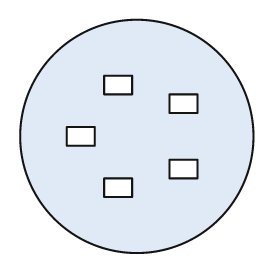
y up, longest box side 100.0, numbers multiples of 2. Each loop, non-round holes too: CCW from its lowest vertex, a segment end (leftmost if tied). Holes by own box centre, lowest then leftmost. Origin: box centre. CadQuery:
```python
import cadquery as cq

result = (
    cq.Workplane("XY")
    .moveTo(0.0, 0.0)
    .circle(50.0)
    .moveTo(-14.0, -26.0)
    .lineTo(-2.0, -26.0)
    .lineTo(-2.0, -18.0)
    .lineTo(-14.0, -18.0)
    .close()
    .moveTo(14.0, -18.0)
    .lineTo(26.0, -18.0)
    .lineTo(26.0, -10.0)
    .lineTo(14.0, -10.0)
    .close()
    .moveTo(-30.0, -4.0)
    .lineTo(-18.0, -4.0)
    .lineTo(-18.0, 4.0)
    .lineTo(-30.0, 4.0)
    .close()
    .moveTo(14.0, 10.0)
    .lineTo(26.0, 10.0)
    .lineTo(26.0, 18.0)
    .lineTo(14.0, 18.0)
    .close()
    .moveTo(-14.0, 18.0)
    .lineTo(-2.0, 18.0)
    .lineTo(-2.0, 26.0)
    .lineTo(-14.0, 26.0)
    .close()
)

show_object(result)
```